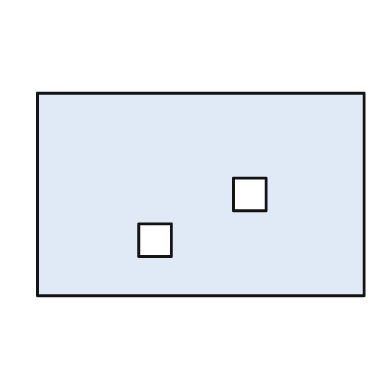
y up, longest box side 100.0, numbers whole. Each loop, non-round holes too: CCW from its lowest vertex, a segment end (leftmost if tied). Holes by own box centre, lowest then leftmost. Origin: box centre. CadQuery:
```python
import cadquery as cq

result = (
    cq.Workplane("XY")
    .moveTo(-50.0, -31.0)
    .lineTo(50.0, -31.0)
    .lineTo(50.0, 31.0)
    .lineTo(-50.0, 31.0)
    .close()
    .moveTo(-19.0, -19.0)
    .lineTo(-9.0, -19.0)
    .lineTo(-9.0, -9.0)
    .lineTo(-19.0, -9.0)
    .close()
    .moveTo(10.0, -5.0)
    .lineTo(20.0, -5.0)
    .lineTo(20.0, 5.0)
    .lineTo(10.0, 5.0)
    .close()
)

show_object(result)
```